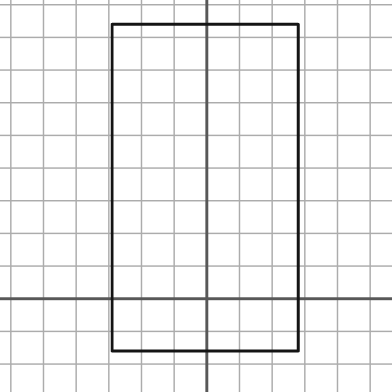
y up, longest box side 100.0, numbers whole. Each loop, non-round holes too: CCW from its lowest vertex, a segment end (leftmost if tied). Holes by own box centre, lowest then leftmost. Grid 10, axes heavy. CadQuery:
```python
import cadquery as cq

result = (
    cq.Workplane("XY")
    .moveTo(-29.0, -16.0)
    .lineTo(28.0, -16.0)
    .lineTo(28.0, 84.0)
    .lineTo(-29.0, 84.0)
    .close()
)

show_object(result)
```